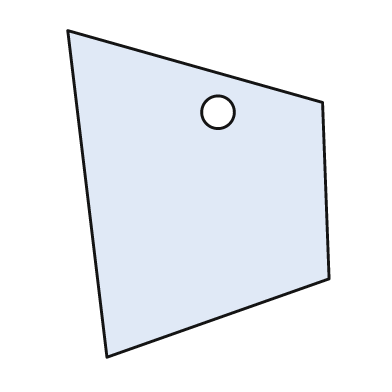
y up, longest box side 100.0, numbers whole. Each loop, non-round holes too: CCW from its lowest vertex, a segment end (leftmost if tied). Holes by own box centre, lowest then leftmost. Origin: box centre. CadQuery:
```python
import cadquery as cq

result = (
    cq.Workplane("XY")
    .moveTo(-28.0, -50.0)
    .lineTo(40.0, -26.0)
    .lineTo(38.0, 28.0)
    .lineTo(-40.0, 50.0)
    .close()
    .moveTo(6.0, 25.0)
    .circle(5.0)
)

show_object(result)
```